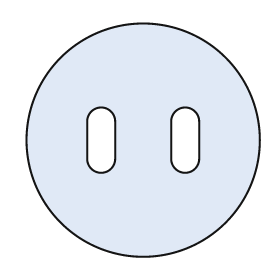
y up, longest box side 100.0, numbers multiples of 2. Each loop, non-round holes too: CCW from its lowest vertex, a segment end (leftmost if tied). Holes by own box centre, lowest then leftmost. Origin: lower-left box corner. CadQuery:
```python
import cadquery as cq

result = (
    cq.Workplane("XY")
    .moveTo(50.0, 50.0)
    .circle(50.0)
    .moveTo(26.0, 42.0)
    .threePointArc((32.0, 36.0), (38.0, 42.0))
    .lineTo(38.0, 58.0)
    .threePointArc((32.0, 64.0), (26.0, 58.0))
    .close()
    .moveTo(62.0, 42.0)
    .threePointArc((68.0, 36.0), (74.0, 42.0))
    .lineTo(74.0, 58.0)
    .threePointArc((68.0, 64.0), (62.0, 58.0))
    .close()
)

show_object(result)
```